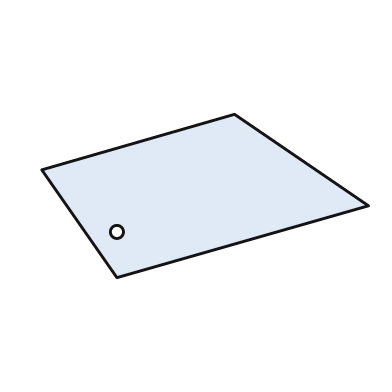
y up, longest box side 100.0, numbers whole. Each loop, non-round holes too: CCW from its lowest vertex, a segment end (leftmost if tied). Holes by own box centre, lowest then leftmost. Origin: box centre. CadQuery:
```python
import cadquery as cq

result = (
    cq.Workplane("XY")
    .moveTo(-27.0, -25.0)
    .lineTo(50.0, -3.0)
    .lineTo(9.0, 25.0)
    .lineTo(-50.0, 8.0)
    .close()
    .moveTo(-27.0, -11.0)
    .circle(2.0)
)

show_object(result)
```